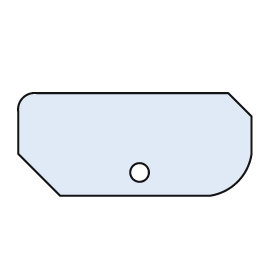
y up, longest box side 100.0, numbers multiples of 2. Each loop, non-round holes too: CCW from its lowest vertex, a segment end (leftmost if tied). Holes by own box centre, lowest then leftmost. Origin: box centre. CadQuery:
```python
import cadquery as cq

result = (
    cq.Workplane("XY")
    .moveTo(-32.0, -22.0)
    .lineTo(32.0, -22.0)
    .threePointArc((44.0, -16.0), (50.0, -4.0))
    .lineTo(50.0, 12.0)
    .lineTo(40.0, 22.0)
    .lineTo(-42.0, 22.0)
    .threePointArc((-48.0, 20.0), (-50.0, 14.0))
    .lineTo(-50.0, -4.0)
    .close()
    .moveTo(2.0, -12.0)
    .circle(4.0)
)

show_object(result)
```